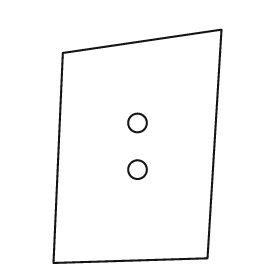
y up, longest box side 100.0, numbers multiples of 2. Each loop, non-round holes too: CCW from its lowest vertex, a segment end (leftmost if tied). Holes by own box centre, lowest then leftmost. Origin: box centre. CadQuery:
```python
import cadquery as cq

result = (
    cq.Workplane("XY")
    .moveTo(-36.0, -50.0)
    .lineTo(30.0, -48.0)
    .lineTo(36.0, 50.0)
    .lineTo(-32.0, 40.0)
    .close()
    .moveTo(0.0, -10.0)
    .circle(4.0)
    .moveTo(0.0, 10.0)
    .circle(4.0)
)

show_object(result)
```